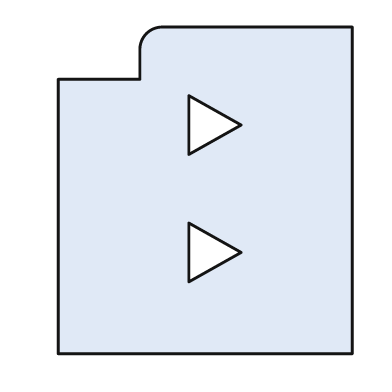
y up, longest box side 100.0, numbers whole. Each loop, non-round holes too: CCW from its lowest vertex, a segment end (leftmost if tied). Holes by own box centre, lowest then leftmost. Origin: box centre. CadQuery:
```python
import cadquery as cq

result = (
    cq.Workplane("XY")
    .moveTo(-45.0, -50.0)
    .lineTo(45.0, -50.0)
    .lineTo(45.0, 50.0)
    .lineTo(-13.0, 50.0)
    .threePointArc((-18.0, 48.0), (-20.0, 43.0))
    .lineTo(-20.0, 34.0)
    .lineTo(-45.0, 34.0)
    .close()
    .moveTo(-5.0, -28.0)
    .lineTo(11.0, -19.0)
    .lineTo(-5.0, -10.0)
    .close()
    .moveTo(-5.0, 11.0)
    .lineTo(11.0, 20.0)
    .lineTo(-5.0, 29.0)
    .close()
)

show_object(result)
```